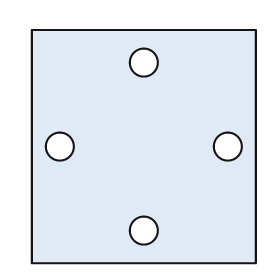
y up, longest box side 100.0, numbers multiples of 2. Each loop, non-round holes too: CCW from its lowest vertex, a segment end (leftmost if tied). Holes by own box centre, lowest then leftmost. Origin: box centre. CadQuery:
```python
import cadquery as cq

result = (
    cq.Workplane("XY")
    .moveTo(-48.0, -50.0)
    .lineTo(48.0, -50.0)
    .lineTo(48.0, 50.0)
    .lineTo(-48.0, 50.0)
    .close()
    .moveTo(0.0, -36.0)
    .circle(6.0)
    .moveTo(-36.0, 0.0)
    .circle(6.0)
    .moveTo(36.0, 0.0)
    .circle(6.0)
    .moveTo(0.0, 36.0)
    .circle(6.0)
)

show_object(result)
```